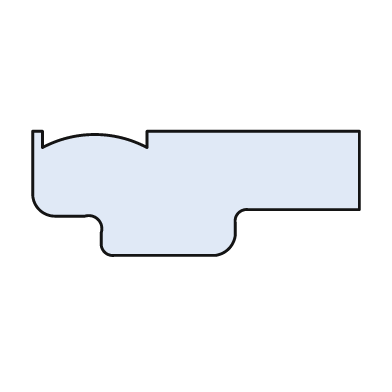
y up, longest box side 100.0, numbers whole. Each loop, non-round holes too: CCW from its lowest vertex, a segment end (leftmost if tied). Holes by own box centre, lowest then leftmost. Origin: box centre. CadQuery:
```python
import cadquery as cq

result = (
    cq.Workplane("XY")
    .moveTo(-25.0, -19.0)
    .lineTo(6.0, -19.0)
    .threePointArc((10.0, -17.0), (12.0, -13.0))
    .lineTo(12.0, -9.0)
    .threePointArc((13.0, -6.0), (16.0, -5.0))
    .lineTo(50.0, -5.0)
    .lineTo(50.0, 19.0)
    .lineTo(-15.0, 19.0)
    .lineTo(-15.0, 14.0)
    .threePointArc((-31.0, 18.0), (-47.0, 14.0))
    .lineTo(-47.0, 19.0)
    .lineTo(-50.0, 19.0)
    .lineTo(-50.0, 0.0)
    .threePointArc((-48.0, -5.0), (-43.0, -7.0))
    .lineTo(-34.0, -7.0)
    .threePointArc((-30.0, -8.0), (-29.0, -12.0))
    .lineTo(-29.0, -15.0)
    .threePointArc((-28.0, -18.0), (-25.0, -19.0))
    .close()
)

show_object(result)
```